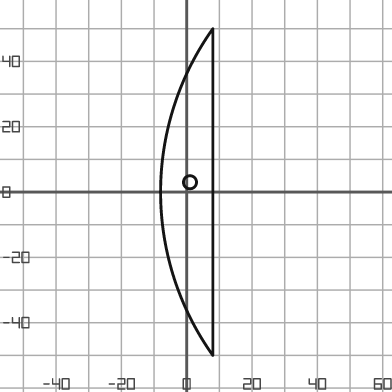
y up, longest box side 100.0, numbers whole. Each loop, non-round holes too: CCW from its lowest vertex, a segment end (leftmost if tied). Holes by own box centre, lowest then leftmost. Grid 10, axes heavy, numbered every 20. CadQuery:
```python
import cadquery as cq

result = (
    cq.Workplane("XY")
    .moveTo(8.0, -50.0)
    .lineTo(8.0, 50.0)
    .threePointArc((-8.0, 0.0), (8.0, -50.0))
    .close()
    .moveTo(1.0, 3.0)
    .circle(2.0)
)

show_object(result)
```